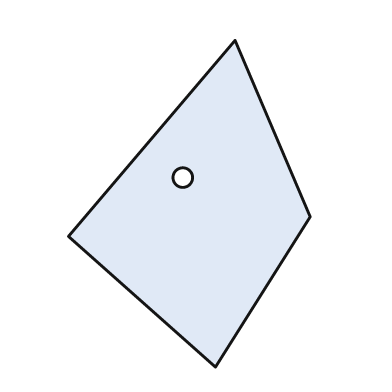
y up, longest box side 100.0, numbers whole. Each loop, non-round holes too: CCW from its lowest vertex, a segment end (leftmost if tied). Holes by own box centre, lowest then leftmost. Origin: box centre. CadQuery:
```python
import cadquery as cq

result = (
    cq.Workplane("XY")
    .moveTo(8.0, -50.0)
    .lineTo(37.0, -4.0)
    .lineTo(14.0, 50.0)
    .lineTo(-37.0, -10.0)
    .close()
    .moveTo(-2.0, 8.0)
    .circle(3.0)
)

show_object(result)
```